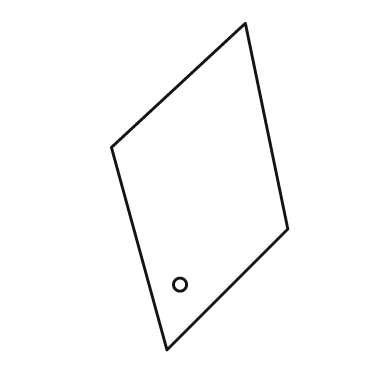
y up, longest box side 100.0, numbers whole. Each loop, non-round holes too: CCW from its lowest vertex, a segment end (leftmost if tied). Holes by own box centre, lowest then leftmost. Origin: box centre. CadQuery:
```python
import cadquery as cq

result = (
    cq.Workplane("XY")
    .moveTo(-10.0, -50.0)
    .lineTo(27.0, -13.0)
    .lineTo(14.0, 50.0)
    .lineTo(-27.0, 12.0)
    .close()
    .moveTo(-6.0, -30.0)
    .circle(2.0)
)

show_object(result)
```